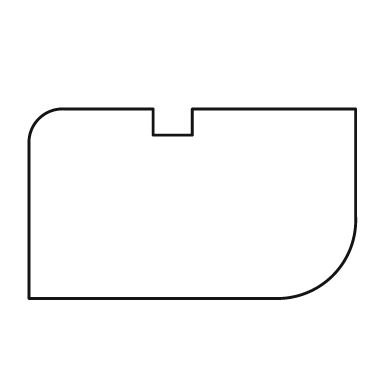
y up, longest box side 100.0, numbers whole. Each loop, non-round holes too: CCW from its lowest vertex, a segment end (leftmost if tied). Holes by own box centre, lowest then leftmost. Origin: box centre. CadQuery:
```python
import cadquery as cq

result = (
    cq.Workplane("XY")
    .moveTo(-50.0, -29.0)
    .lineTo(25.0, -29.0)
    .threePointArc((43.0, -22.0), (50.0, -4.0))
    .lineTo(50.0, 29.0)
    .lineTo(0.0, 29.0)
    .lineTo(0.0, 21.0)
    .lineTo(-12.0, 21.0)
    .lineTo(-12.0, 29.0)
    .lineTo(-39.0, 29.0)
    .threePointArc((-47.0, 26.0), (-50.0, 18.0))
    .close()
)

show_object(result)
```